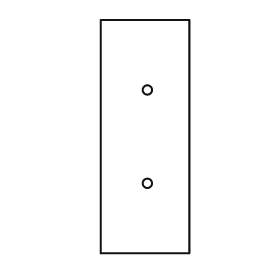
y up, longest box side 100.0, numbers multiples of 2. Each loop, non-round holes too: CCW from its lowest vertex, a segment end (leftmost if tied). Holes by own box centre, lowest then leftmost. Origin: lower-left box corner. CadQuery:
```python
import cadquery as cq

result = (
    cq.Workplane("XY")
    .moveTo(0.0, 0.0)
    .lineTo(38.0, 0.0)
    .lineTo(38.0, 100.0)
    .lineTo(0.0, 100.0)
    .close()
    .moveTo(20.0, 30.0)
    .circle(2.0)
    .moveTo(20.0, 70.0)
    .circle(2.0)
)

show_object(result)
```